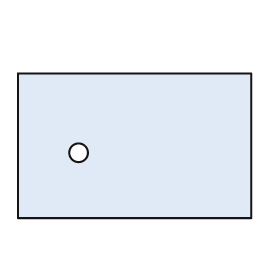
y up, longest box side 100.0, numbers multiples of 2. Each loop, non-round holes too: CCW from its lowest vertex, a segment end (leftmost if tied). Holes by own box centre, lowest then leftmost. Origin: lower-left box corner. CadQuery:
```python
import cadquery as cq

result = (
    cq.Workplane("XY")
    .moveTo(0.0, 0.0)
    .lineTo(100.0, 0.0)
    .lineTo(100.0, 62.0)
    .lineTo(0.0, 62.0)
    .close()
    .moveTo(26.0, 28.0)
    .circle(4.0)
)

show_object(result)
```